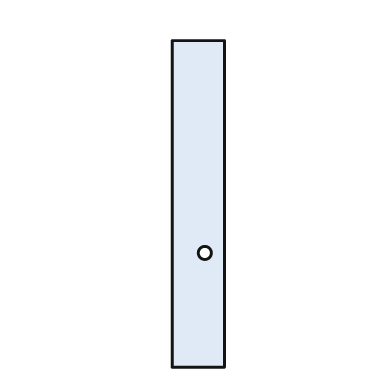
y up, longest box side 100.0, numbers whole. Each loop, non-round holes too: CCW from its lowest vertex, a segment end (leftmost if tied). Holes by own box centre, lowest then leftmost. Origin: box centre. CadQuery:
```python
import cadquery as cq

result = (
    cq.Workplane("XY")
    .moveTo(-8.0, -50.0)
    .lineTo(8.0, -50.0)
    .lineTo(8.0, 50.0)
    .lineTo(-8.0, 50.0)
    .close()
    .moveTo(2.0, -15.0)
    .circle(2.0)
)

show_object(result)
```